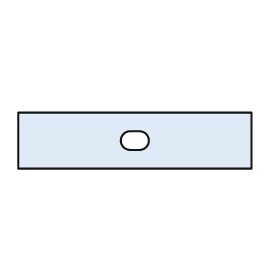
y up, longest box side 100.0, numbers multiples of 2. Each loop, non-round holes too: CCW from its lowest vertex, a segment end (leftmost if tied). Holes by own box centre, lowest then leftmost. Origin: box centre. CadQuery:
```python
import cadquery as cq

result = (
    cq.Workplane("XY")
    .moveTo(-50.0, -12.0)
    .lineTo(50.0, -12.0)
    .lineTo(50.0, 12.0)
    .lineTo(-50.0, 12.0)
    .close()
    .moveTo(-2.0, -4.0)
    .lineTo(2.0, -4.0)
    .threePointArc((6.0, 0.0), (2.0, 4.0))
    .lineTo(-2.0, 4.0)
    .threePointArc((-6.0, 0.0), (-2.0, -4.0))
    .close()
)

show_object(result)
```